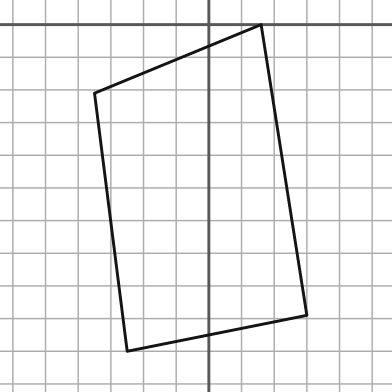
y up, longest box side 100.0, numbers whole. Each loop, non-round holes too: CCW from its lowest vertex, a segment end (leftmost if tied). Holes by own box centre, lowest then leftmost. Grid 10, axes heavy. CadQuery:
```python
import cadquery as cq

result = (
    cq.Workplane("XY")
    .moveTo(-25.0, -100.0)
    .lineTo(30.0, -89.0)
    .lineTo(16.0, 0.0)
    .lineTo(-35.0, -21.0)
    .close()
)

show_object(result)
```